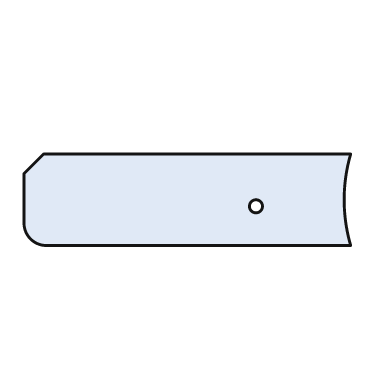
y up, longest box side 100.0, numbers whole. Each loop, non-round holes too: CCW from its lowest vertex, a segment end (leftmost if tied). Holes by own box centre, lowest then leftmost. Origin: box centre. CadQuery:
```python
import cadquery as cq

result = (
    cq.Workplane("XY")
    .moveTo(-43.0, -14.0)
    .lineTo(50.0, -14.0)
    .threePointArc((48.0, 0.0), (50.0, 14.0))
    .lineTo(-44.0, 14.0)
    .lineTo(-50.0, 8.0)
    .lineTo(-50.0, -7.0)
    .threePointArc((-48.0, -12.0), (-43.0, -14.0))
    .close()
    .moveTo(21.0, -2.0)
    .circle(2.0)
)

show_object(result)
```